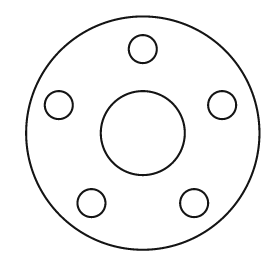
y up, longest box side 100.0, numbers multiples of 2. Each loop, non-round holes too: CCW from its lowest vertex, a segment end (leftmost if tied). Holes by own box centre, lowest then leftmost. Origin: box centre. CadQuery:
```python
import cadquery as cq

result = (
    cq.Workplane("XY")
    .moveTo(0.0, 0.0)
    .circle(50.0)
    .moveTo(-22.0, -30.0)
    .circle(6.0)
    .moveTo(22.0, -30.0)
    .circle(6.0)
    .moveTo(0.0, 0.0)
    .circle(18.0)
    .moveTo(-36.0, 12.0)
    .circle(6.0)
    .moveTo(34.0, 12.0)
    .circle(6.0)
    .moveTo(0.0, 36.0)
    .circle(6.0)
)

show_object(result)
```